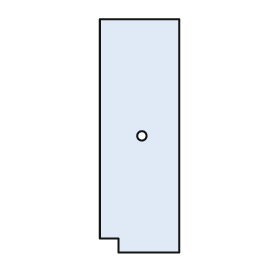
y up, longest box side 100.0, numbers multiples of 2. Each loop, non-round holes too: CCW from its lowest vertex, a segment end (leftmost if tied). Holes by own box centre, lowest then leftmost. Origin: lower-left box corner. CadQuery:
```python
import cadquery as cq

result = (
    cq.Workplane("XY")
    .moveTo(8.0, 0.0)
    .lineTo(34.0, 0.0)
    .lineTo(34.0, 100.0)
    .lineTo(0.0, 100.0)
    .lineTo(0.0, 6.0)
    .lineTo(8.0, 6.0)
    .close()
    .moveTo(18.0, 50.0)
    .circle(2.0)
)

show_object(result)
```